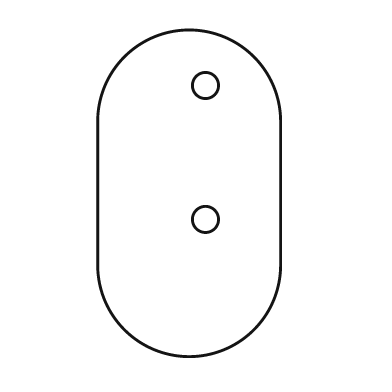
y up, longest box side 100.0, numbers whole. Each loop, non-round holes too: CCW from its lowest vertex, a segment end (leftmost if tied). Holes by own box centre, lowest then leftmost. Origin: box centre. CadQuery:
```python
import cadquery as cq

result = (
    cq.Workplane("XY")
    .moveTo(-28.0, -22.0)
    .threePointArc((0.0, -50.0), (28.0, -22.0))
    .lineTo(28.0, 22.0)
    .threePointArc((0.0, 50.0), (-28.0, 22.0))
    .close()
    .moveTo(5.0, -8.0)
    .circle(4.0)
    .moveTo(5.0, 33.0)
    .circle(4.0)
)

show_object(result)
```